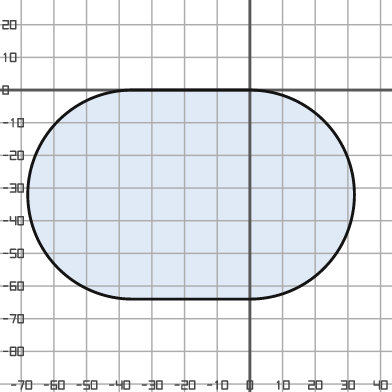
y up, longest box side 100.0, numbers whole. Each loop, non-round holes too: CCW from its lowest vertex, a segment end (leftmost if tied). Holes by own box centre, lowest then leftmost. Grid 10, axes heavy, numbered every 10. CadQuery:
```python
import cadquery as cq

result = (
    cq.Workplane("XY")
    .moveTo(-36.0, -64.0)
    .lineTo(0.0, -64.0)
    .threePointArc((32.0, -32.0), (0.0, 0.0))
    .lineTo(-36.0, 0.0)
    .threePointArc((-68.0, -32.0), (-36.0, -64.0))
    .close()
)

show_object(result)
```